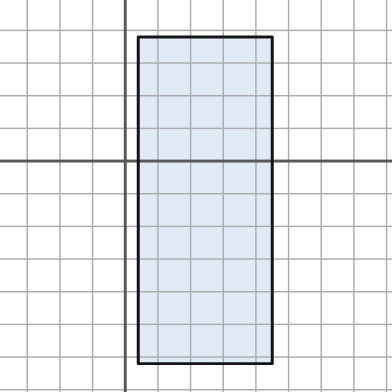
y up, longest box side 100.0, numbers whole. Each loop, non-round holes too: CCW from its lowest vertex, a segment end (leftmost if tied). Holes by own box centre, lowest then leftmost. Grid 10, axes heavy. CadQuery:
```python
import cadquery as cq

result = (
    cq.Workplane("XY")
    .moveTo(4.0, -62.0)
    .lineTo(45.0, -62.0)
    .lineTo(45.0, 38.0)
    .lineTo(4.0, 38.0)
    .close()
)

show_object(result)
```